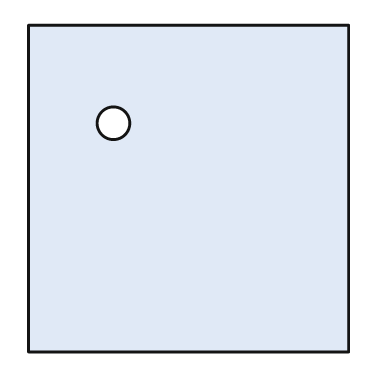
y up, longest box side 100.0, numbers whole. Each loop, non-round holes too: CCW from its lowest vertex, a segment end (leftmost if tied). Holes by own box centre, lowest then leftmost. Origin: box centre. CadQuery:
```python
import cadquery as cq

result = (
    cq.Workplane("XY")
    .moveTo(-49.0, -50.0)
    .lineTo(49.0, -50.0)
    .lineTo(49.0, 50.0)
    .lineTo(-49.0, 50.0)
    .close()
    .moveTo(-23.0, 20.0)
    .circle(5.0)
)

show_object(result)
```